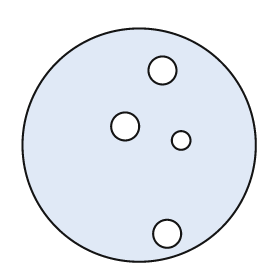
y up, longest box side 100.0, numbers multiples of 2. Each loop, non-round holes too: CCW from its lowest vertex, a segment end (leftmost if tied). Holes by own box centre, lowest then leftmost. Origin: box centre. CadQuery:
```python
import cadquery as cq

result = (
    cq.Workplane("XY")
    .moveTo(0.0, 0.0)
    .circle(50.0)
    .moveTo(12.0, -38.0)
    .circle(6.0)
    .moveTo(18.0, 2.0)
    .circle(4.0)
    .moveTo(-6.0, 8.0)
    .circle(6.0)
    .moveTo(10.0, 32.0)
    .circle(6.0)
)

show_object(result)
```